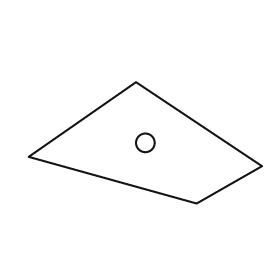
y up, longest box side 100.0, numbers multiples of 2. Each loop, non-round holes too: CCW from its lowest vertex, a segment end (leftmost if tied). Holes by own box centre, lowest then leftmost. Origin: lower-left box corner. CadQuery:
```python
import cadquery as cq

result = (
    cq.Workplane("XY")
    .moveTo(72.0, 0.0)
    .lineTo(100.0, 16.0)
    .lineTo(46.0, 52.0)
    .lineTo(0.0, 20.0)
    .close()
    .moveTo(50.0, 26.0)
    .circle(4.0)
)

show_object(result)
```